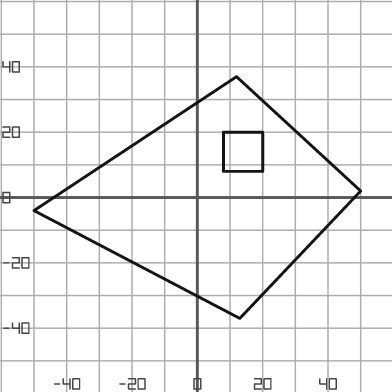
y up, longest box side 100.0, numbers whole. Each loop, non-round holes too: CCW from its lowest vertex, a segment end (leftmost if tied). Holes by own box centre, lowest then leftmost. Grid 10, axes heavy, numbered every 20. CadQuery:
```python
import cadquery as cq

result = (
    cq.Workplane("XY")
    .moveTo(13.0, -37.0)
    .lineTo(50.0, 2.0)
    .lineTo(12.0, 37.0)
    .lineTo(-50.0, -4.0)
    .close()
    .moveTo(8.0, 8.0)
    .lineTo(20.0, 8.0)
    .lineTo(20.0, 20.0)
    .lineTo(8.0, 20.0)
    .close()
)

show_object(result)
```